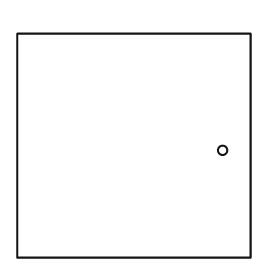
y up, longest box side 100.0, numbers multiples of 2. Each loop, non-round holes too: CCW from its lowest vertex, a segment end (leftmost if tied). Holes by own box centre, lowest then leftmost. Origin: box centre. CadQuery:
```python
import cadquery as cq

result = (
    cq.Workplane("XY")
    .moveTo(-50.0, -48.0)
    .lineTo(50.0, -48.0)
    .lineTo(50.0, 48.0)
    .lineTo(-50.0, 48.0)
    .close()
    .moveTo(38.0, -2.0)
    .circle(2.0)
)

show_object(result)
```